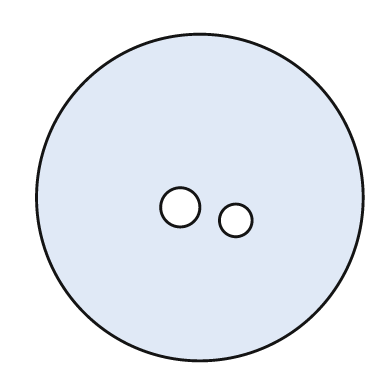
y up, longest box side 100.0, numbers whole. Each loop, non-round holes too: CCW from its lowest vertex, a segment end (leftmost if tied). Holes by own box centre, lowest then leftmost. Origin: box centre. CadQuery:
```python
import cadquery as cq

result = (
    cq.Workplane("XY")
    .moveTo(0.0, 0.0)
    .circle(50.0)
    .moveTo(11.0, -7.0)
    .circle(5.0)
    .moveTo(-6.0, -3.0)
    .circle(6.0)
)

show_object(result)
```